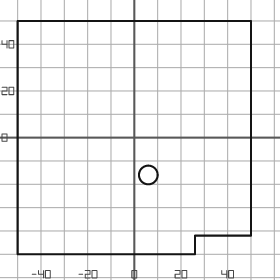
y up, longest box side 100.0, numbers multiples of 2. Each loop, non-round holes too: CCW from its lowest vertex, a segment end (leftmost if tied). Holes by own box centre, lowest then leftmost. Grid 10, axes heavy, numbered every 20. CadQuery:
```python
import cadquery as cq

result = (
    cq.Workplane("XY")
    .moveTo(-50.0, -50.0)
    .lineTo(26.0, -50.0)
    .lineTo(26.0, -42.0)
    .lineTo(50.0, -42.0)
    .lineTo(50.0, 50.0)
    .lineTo(-50.0, 50.0)
    .close()
    .moveTo(6.0, -16.0)
    .circle(4.0)
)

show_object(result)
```